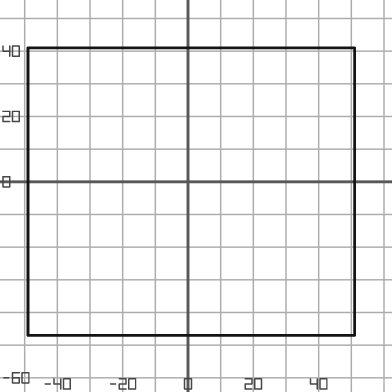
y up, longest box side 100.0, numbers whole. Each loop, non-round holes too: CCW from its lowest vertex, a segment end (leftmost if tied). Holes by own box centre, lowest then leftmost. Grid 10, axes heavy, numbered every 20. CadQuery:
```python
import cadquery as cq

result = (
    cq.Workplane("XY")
    .moveTo(-49.0, -47.0)
    .lineTo(51.0, -47.0)
    .lineTo(51.0, 41.0)
    .lineTo(-49.0, 41.0)
    .close()
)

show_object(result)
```